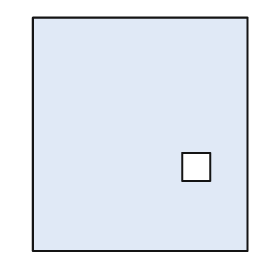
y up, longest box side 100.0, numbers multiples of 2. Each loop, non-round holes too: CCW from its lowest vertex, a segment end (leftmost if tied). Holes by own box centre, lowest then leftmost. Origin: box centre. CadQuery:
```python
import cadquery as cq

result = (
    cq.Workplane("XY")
    .moveTo(-46.0, -50.0)
    .lineTo(46.0, -50.0)
    .lineTo(46.0, 50.0)
    .lineTo(-46.0, 50.0)
    .close()
    .moveTo(18.0, -20.0)
    .lineTo(30.0, -20.0)
    .lineTo(30.0, -8.0)
    .lineTo(18.0, -8.0)
    .close()
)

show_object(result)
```